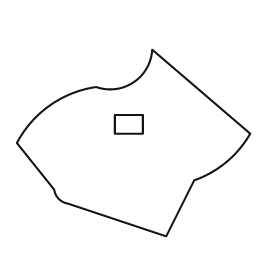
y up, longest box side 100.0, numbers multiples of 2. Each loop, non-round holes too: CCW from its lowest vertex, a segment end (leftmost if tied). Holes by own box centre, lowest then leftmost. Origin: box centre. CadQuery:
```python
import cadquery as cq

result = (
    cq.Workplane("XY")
    .moveTo(14.0, -40.0)
    .lineTo(26.0, -16.0)
    .threePointArc((40.0, -8.0), (50.0, 4.0))
    .lineTo(8.0, 40.0)
    .threePointArc((0.0, 26.0), (-16.0, 24.0))
    .threePointArc((-36.0, 16.0), (-50.0, 0.0))
    .lineTo(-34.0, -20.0)
    .threePointArc((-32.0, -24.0), (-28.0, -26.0))
    .close()
    .moveTo(-8.0, 4.0)
    .lineTo(4.0, 4.0)
    .lineTo(4.0, 12.0)
    .lineTo(-8.0, 12.0)
    .close()
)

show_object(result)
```